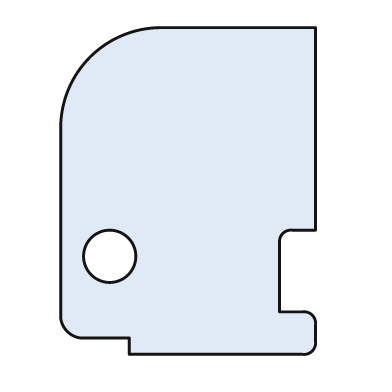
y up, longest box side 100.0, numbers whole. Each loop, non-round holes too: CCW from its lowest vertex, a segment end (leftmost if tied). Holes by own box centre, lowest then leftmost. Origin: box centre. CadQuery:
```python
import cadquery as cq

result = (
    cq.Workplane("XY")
    .moveTo(-18.0, -50.0)
    .lineTo(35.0, -50.0)
    .threePointArc((38.0, -49.0), (39.0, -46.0))
    .lineTo(39.0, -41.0)
    .threePointArc((38.0, -38.0), (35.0, -37.0))
    .lineTo(28.0, -37.0)
    .lineTo(28.0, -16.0)
    .threePointArc((29.0, -13.0), (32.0, -12.0))
    .lineTo(39.0, -12.0)
    .lineTo(39.0, 50.0)
    .lineTo(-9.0, 50.0)
    .threePointArc((-30.0, 41.0), (-39.0, 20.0))
    .lineTo(-39.0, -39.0)
    .threePointArc((-37.0, -43.0), (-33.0, -45.0))
    .lineTo(-18.0, -45.0)
    .close()
    .moveTo(-24.0, -20.0)
    .circle(8.0)
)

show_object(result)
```